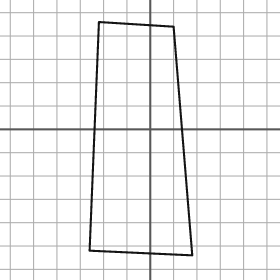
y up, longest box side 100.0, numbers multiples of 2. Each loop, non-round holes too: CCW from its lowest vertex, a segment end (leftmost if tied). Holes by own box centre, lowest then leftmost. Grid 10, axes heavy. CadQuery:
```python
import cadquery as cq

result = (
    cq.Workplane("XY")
    .moveTo(18.0, -54.0)
    .lineTo(10.0, 44.0)
    .lineTo(-22.0, 46.0)
    .lineTo(-26.0, -52.0)
    .close()
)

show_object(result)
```